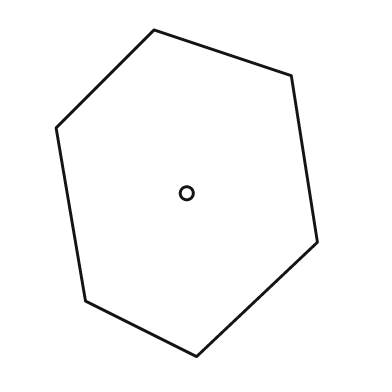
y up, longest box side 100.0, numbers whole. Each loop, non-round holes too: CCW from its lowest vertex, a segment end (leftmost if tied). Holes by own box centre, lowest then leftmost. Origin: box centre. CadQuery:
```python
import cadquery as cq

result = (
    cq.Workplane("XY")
    .moveTo(3.0, -50.0)
    .lineTo(40.0, -15.0)
    .lineTo(32.0, 36.0)
    .lineTo(-10.0, 50.0)
    .lineTo(-40.0, 20.0)
    .lineTo(-31.0, -33.0)
    .close()
    .moveTo(0.0, 0.0)
    .circle(2.0)
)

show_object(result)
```